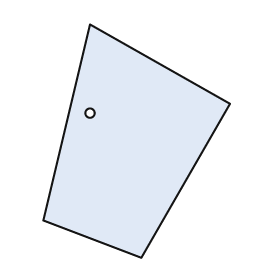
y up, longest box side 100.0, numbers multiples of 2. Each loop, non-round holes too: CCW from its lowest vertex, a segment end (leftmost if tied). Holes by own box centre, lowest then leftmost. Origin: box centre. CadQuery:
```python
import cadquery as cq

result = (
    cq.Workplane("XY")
    .moveTo(2.0, -50.0)
    .lineTo(40.0, 16.0)
    .lineTo(-20.0, 50.0)
    .lineTo(-40.0, -34.0)
    .close()
    .moveTo(-20.0, 12.0)
    .circle(2.0)
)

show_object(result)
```